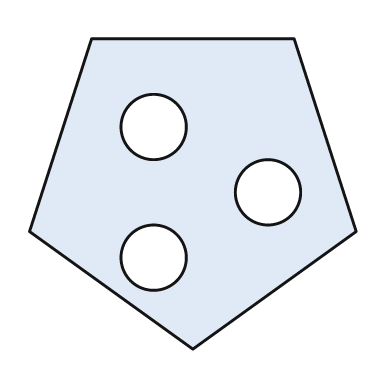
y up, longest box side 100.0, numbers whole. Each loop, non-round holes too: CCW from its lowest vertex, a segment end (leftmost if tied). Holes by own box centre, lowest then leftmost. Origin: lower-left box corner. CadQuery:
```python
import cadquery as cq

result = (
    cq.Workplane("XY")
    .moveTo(50.0, 0.0)
    .lineTo(100.0, 36.0)
    .lineTo(81.0, 95.0)
    .lineTo(19.0, 95.0)
    .lineTo(0.0, 36.0)
    .close()
    .moveTo(38.0, 28.0)
    .circle(10.0)
    .moveTo(73.0, 48.0)
    .circle(10.0)
    .moveTo(38.0, 68.0)
    .circle(10.0)
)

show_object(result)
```